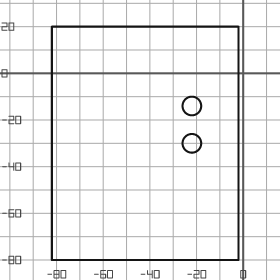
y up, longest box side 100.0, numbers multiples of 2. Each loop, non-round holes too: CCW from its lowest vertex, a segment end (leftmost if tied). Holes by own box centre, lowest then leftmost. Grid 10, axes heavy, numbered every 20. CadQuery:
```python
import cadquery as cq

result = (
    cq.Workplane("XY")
    .moveTo(-82.0, -80.0)
    .lineTo(-2.0, -80.0)
    .lineTo(-2.0, 20.0)
    .lineTo(-82.0, 20.0)
    .close()
    .moveTo(-22.0, -30.0)
    .circle(4.0)
    .moveTo(-22.0, -14.0)
    .circle(4.0)
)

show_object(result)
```